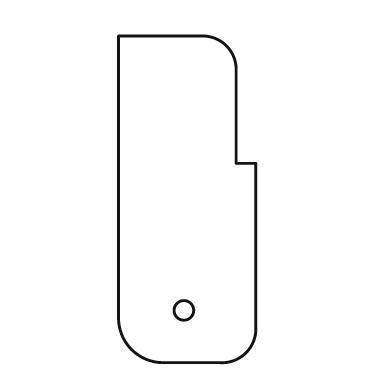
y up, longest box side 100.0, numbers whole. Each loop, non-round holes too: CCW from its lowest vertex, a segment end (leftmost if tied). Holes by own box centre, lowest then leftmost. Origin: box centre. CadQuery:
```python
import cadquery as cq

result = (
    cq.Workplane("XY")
    .moveTo(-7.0, -50.0)
    .lineTo(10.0, -50.0)
    .threePointArc((18.0, -47.0), (21.0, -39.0))
    .lineTo(21.0, 11.0)
    .lineTo(15.0, 11.0)
    .lineTo(15.0, 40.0)
    .threePointArc((12.0, 47.0), (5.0, 50.0))
    .lineTo(-21.0, 50.0)
    .lineTo(-21.0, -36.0)
    .threePointArc((-17.0, -46.0), (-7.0, -50.0))
    .close()
    .moveTo(-1.0, -34.0)
    .circle(3.0)
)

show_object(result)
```